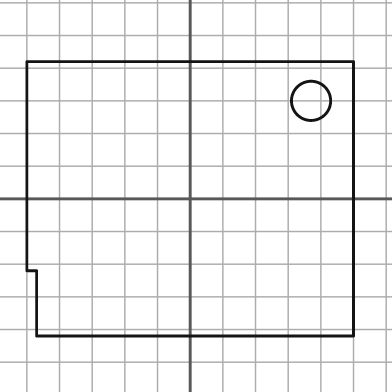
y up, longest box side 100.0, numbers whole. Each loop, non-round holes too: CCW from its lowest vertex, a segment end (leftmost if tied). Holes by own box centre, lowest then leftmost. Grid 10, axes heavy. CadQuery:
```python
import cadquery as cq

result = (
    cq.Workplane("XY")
    .moveTo(-47.0, -42.0)
    .lineTo(50.0, -42.0)
    .lineTo(50.0, 42.0)
    .lineTo(-50.0, 42.0)
    .lineTo(-50.0, -22.0)
    .lineTo(-47.0, -22.0)
    .close()
    .moveTo(37.0, 30.0)
    .circle(6.0)
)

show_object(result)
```